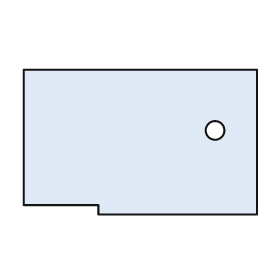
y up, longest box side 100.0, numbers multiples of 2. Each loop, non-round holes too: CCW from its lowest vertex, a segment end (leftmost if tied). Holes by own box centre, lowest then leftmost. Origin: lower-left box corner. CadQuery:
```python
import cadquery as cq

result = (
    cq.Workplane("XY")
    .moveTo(32.0, 0.0)
    .lineTo(100.0, 0.0)
    .lineTo(100.0, 62.0)
    .lineTo(0.0, 62.0)
    .lineTo(0.0, 4.0)
    .lineTo(32.0, 4.0)
    .close()
    .moveTo(82.0, 36.0)
    .circle(4.0)
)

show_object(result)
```